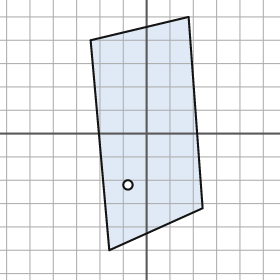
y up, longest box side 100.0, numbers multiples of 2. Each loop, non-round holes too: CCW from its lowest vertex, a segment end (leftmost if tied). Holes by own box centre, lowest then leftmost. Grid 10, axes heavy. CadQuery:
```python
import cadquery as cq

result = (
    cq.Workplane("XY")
    .moveTo(-16.0, -50.0)
    .lineTo(24.0, -32.0)
    .lineTo(18.0, 50.0)
    .lineTo(-24.0, 40.0)
    .close()
    .moveTo(-8.0, -22.0)
    .circle(2.0)
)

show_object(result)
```